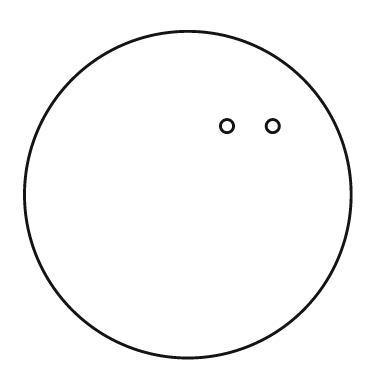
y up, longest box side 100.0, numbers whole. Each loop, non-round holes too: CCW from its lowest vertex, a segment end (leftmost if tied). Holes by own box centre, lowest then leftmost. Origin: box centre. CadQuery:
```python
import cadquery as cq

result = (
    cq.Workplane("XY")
    .moveTo(0.0, 0.0)
    .circle(50.0)
    .moveTo(12.0, 21.0)
    .circle(2.0)
    .moveTo(26.0, 21.0)
    .circle(2.0)
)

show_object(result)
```